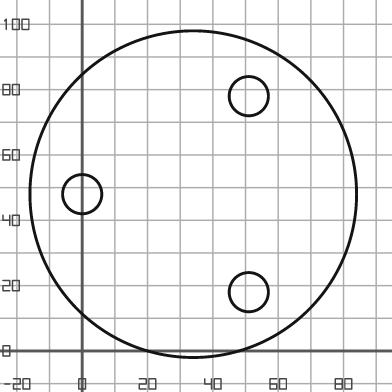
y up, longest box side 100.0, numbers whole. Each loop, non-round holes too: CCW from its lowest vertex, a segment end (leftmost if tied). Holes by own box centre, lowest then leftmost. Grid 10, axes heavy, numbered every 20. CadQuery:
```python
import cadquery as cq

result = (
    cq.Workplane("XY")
    .moveTo(34.0, 48.0)
    .circle(50.0)
    .moveTo(51.0, 18.0)
    .circle(6.0)
    .moveTo(0.0, 48.0)
    .circle(6.0)
    .moveTo(51.0, 78.0)
    .circle(6.0)
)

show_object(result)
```